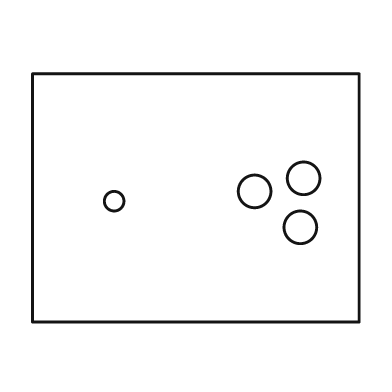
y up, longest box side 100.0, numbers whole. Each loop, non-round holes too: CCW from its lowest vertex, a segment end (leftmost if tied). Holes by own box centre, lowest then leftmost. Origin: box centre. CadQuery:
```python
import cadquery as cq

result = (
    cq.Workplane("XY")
    .moveTo(-50.0, -38.0)
    .lineTo(50.0, -38.0)
    .lineTo(50.0, 38.0)
    .lineTo(-50.0, 38.0)
    .close()
    .moveTo(32.0, -9.0)
    .circle(5.0)
    .moveTo(-25.0, -1.0)
    .circle(3.0)
    .moveTo(18.0, 2.0)
    .circle(5.0)
    .moveTo(33.0, 6.0)
    .circle(5.0)
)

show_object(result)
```